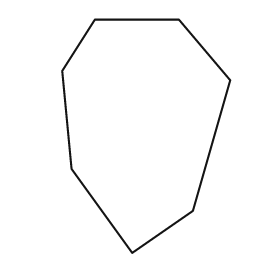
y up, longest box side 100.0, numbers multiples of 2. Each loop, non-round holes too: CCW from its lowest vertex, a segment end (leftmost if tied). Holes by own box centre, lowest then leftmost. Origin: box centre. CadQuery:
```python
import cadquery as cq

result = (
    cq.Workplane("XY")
    .moveTo(-6.0, -50.0)
    .lineTo(20.0, -32.0)
    .lineTo(36.0, 24.0)
    .lineTo(14.0, 50.0)
    .lineTo(-22.0, 50.0)
    .lineTo(-36.0, 28.0)
    .lineTo(-32.0, -14.0)
    .close()
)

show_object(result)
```